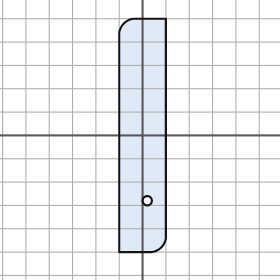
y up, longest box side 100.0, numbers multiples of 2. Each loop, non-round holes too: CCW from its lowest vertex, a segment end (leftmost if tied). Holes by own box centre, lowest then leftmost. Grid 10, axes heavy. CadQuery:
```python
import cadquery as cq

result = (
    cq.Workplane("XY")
    .moveTo(-10.0, -50.0)
    .lineTo(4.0, -50.0)
    .threePointArc((8.0, -48.0), (10.0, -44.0))
    .lineTo(10.0, 50.0)
    .lineTo(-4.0, 50.0)
    .threePointArc((-8.0, 48.0), (-10.0, 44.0))
    .close()
    .moveTo(2.0, -28.0)
    .circle(2.0)
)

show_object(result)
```